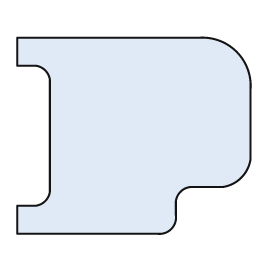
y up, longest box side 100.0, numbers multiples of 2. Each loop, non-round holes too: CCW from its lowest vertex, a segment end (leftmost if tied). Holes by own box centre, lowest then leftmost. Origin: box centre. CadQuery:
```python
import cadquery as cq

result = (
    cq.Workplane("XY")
    .moveTo(-50.0, -42.0)
    .lineTo(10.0, -42.0)
    .threePointArc((16.0, -40.0), (18.0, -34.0))
    .lineTo(18.0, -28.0)
    .threePointArc((20.0, -24.0), (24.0, -22.0))
    .lineTo(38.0, -22.0)
    .threePointArc((46.0, -18.0), (50.0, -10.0))
    .lineTo(50.0, 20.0)
    .threePointArc((44.0, 36.0), (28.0, 42.0))
    .lineTo(-50.0, 42.0)
    .lineTo(-50.0, 30.0)
    .lineTo(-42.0, 30.0)
    .threePointArc((-38.0, 28.0), (-36.0, 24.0))
    .lineTo(-36.0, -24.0)
    .threePointArc((-38.0, -28.0), (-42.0, -30.0))
    .lineTo(-50.0, -30.0)
    .close()
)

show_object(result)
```